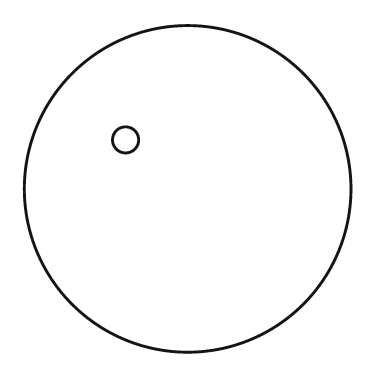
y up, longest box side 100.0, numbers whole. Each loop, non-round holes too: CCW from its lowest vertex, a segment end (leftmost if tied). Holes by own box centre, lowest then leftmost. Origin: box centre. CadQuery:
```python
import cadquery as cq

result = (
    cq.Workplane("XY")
    .moveTo(0.0, 0.0)
    .circle(50.0)
    .moveTo(-19.0, 15.0)
    .circle(4.0)
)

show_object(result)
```